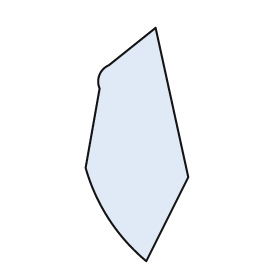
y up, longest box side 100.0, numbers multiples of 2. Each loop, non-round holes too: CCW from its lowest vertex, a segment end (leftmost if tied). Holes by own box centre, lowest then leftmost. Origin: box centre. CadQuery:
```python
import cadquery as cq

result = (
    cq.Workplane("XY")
    .moveTo(4.0, -50.0)
    .lineTo(22.0, -14.0)
    .lineTo(8.0, 50.0)
    .lineTo(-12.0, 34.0)
    .threePointArc((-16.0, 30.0), (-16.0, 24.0))
    .lineTo(-22.0, -10.0)
    .threePointArc((-12.0, -32.0), (4.0, -50.0))
    .close()
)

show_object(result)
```